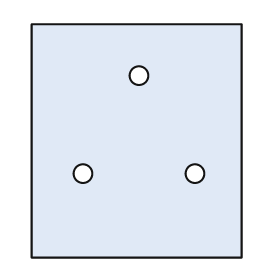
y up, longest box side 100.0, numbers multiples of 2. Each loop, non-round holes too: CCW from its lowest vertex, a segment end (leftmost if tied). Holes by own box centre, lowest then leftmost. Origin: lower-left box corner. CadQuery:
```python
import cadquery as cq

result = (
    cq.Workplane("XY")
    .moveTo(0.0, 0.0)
    .lineTo(90.0, 0.0)
    .lineTo(90.0, 100.0)
    .lineTo(0.0, 100.0)
    .close()
    .moveTo(22.0, 36.0)
    .circle(4.0)
    .moveTo(70.0, 36.0)
    .circle(4.0)
    .moveTo(46.0, 78.0)
    .circle(4.0)
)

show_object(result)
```